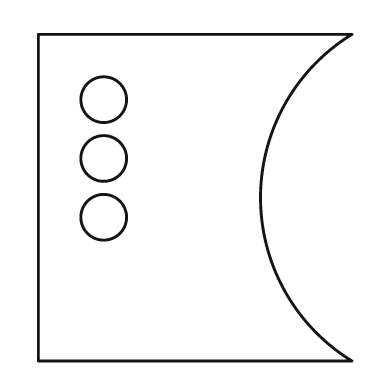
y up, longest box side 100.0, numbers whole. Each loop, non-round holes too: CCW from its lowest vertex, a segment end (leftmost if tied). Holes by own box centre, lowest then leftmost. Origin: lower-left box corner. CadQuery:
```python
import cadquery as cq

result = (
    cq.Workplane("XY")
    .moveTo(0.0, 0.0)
    .lineTo(96.0, 0.0)
    .threePointArc((68.0, 50.0), (96.0, 100.0))
    .lineTo(0.0, 100.0)
    .close()
    .moveTo(20.0, 44.0)
    .circle(7.0)
    .moveTo(20.0, 62.0)
    .circle(7.0)
    .moveTo(20.0, 80.0)
    .circle(7.0)
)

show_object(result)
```